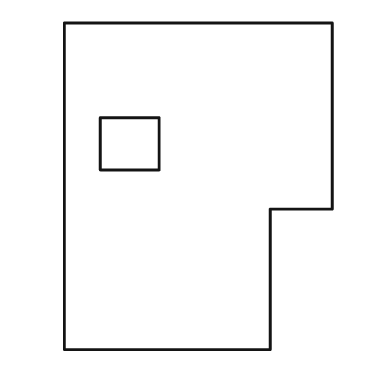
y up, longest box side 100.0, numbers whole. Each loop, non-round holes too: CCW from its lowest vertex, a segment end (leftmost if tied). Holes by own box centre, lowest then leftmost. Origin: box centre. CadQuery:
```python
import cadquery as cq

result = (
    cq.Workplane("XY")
    .moveTo(-41.0, -50.0)
    .lineTo(22.0, -50.0)
    .lineTo(22.0, -7.0)
    .lineTo(41.0, -7.0)
    .lineTo(41.0, 50.0)
    .lineTo(-41.0, 50.0)
    .close()
    .moveTo(-30.0, 5.0)
    .lineTo(-12.0, 5.0)
    .lineTo(-12.0, 21.0)
    .lineTo(-30.0, 21.0)
    .close()
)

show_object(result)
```